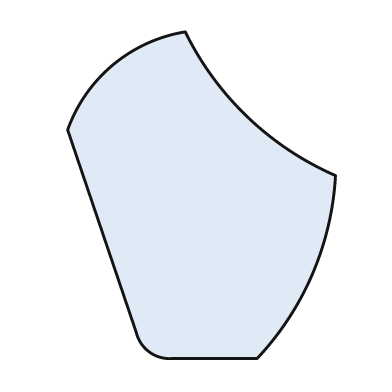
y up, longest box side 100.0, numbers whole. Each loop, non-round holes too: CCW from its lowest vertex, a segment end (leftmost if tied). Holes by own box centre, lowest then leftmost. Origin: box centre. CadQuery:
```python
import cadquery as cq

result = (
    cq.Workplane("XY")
    .moveTo(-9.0, -50.0)
    .lineTo(17.0, -50.0)
    .threePointArc((34.0, -24.0), (41.0, 6.0))
    .threePointArc((14.0, 24.0), (-5.0, 50.0))
    .threePointArc((-27.0, 40.0), (-41.0, 20.0))
    .lineTo(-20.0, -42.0)
    .threePointArc((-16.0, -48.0), (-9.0, -50.0))
    .close()
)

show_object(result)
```